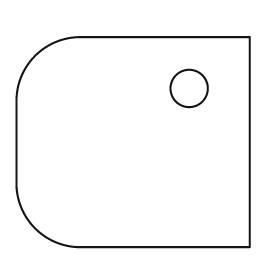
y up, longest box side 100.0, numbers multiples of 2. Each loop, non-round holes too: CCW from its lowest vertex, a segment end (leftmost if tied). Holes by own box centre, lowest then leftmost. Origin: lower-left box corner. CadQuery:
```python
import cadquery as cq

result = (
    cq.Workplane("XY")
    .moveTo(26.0, 0.0)
    .lineTo(100.0, 0.0)
    .lineTo(100.0, 90.0)
    .lineTo(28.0, 90.0)
    .threePointArc((8.0, 82.0), (0.0, 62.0))
    .lineTo(0.0, 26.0)
    .threePointArc((8.0, 8.0), (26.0, 0.0))
    .close()
    .moveTo(74.0, 68.0)
    .circle(8.0)
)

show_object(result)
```